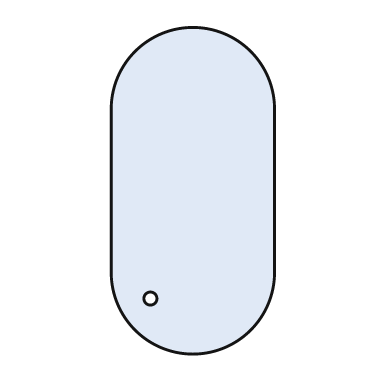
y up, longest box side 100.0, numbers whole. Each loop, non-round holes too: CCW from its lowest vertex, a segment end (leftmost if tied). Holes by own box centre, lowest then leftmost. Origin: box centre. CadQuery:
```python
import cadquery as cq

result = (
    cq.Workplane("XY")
    .moveTo(-25.0, -25.0)
    .threePointArc((0.0, -50.0), (25.0, -25.0))
    .lineTo(25.0, 25.0)
    .threePointArc((0.0, 50.0), (-25.0, 25.0))
    .close()
    .moveTo(-13.0, -33.0)
    .circle(2.0)
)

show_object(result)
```